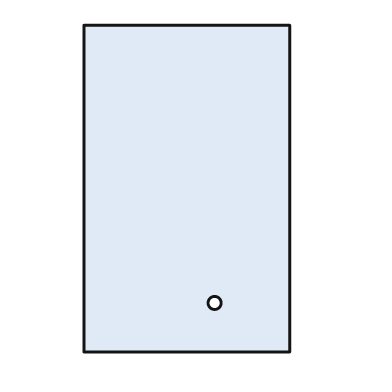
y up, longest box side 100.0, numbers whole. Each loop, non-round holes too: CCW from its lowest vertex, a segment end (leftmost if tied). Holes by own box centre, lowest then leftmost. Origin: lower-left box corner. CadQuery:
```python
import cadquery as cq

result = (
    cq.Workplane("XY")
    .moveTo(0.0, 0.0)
    .lineTo(63.0, 0.0)
    .lineTo(63.0, 100.0)
    .lineTo(0.0, 100.0)
    .close()
    .moveTo(40.0, 15.0)
    .circle(2.0)
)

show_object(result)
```